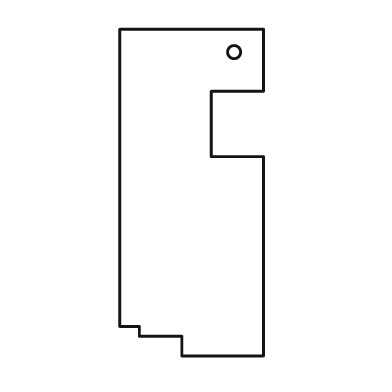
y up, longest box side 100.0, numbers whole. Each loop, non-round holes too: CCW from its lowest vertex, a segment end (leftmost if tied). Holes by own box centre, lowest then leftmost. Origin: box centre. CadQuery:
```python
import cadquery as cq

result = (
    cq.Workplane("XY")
    .moveTo(-3.0, -50.0)
    .lineTo(22.0, -50.0)
    .lineTo(22.0, 11.0)
    .lineTo(6.0, 11.0)
    .lineTo(6.0, 31.0)
    .lineTo(22.0, 31.0)
    .lineTo(22.0, 50.0)
    .lineTo(-22.0, 50.0)
    .lineTo(-22.0, -41.0)
    .lineTo(-16.0, -41.0)
    .lineTo(-16.0, -44.0)
    .lineTo(-3.0, -44.0)
    .close()
    .moveTo(13.0, 43.0)
    .circle(2.0)
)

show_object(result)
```